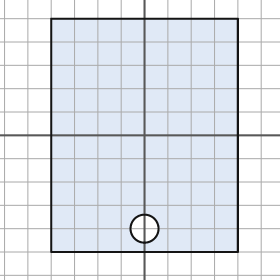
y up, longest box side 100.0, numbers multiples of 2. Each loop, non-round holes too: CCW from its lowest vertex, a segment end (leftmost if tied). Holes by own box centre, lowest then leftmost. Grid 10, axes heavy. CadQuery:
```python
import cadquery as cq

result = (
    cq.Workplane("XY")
    .moveTo(-40.0, -50.0)
    .lineTo(40.0, -50.0)
    .lineTo(40.0, 50.0)
    .lineTo(-40.0, 50.0)
    .close()
    .moveTo(0.0, -40.0)
    .circle(6.0)
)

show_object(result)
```